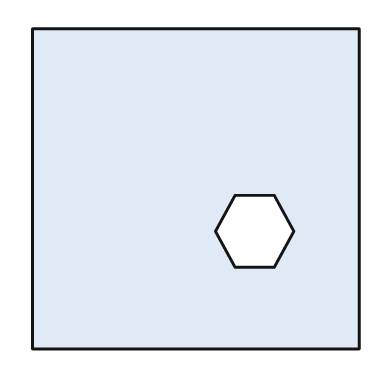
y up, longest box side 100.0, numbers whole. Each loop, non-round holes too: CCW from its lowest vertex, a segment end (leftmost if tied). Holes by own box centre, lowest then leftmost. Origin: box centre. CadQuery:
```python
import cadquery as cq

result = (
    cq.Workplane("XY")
    .moveTo(-50.0, -49.0)
    .lineTo(50.0, -49.0)
    .lineTo(50.0, 49.0)
    .lineTo(-50.0, 49.0)
    .close()
    .moveTo(12.0, -24.0)
    .lineTo(24.0, -24.0)
    .lineTo(30.0, -13.0)
    .lineTo(24.0, -2.0)
    .lineTo(12.0, -2.0)
    .lineTo(6.0, -13.0)
    .close()
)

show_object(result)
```